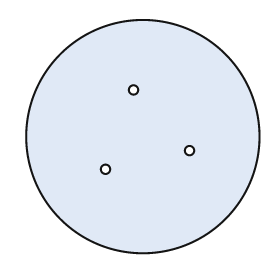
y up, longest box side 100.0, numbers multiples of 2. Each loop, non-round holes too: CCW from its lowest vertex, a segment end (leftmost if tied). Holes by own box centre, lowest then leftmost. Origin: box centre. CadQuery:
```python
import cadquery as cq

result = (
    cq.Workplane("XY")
    .moveTo(0.0, 0.0)
    .circle(50.0)
    .moveTo(-16.0, -14.0)
    .circle(2.0)
    .moveTo(20.0, -6.0)
    .circle(2.0)
    .moveTo(-4.0, 20.0)
    .circle(2.0)
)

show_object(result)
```